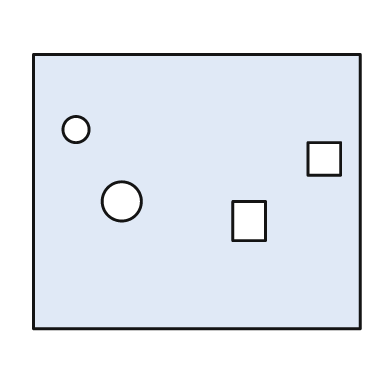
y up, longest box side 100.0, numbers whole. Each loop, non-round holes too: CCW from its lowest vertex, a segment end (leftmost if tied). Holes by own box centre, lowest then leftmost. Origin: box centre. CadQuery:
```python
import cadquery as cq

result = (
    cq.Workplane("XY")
    .moveTo(-50.0, -42.0)
    .lineTo(50.0, -42.0)
    .lineTo(50.0, 42.0)
    .lineTo(-50.0, 42.0)
    .close()
    .moveTo(11.0, -15.0)
    .lineTo(21.0, -15.0)
    .lineTo(21.0, -3.0)
    .lineTo(11.0, -3.0)
    .close()
    .moveTo(-23.0, -3.0)
    .circle(6.0)
    .moveTo(34.0, 5.0)
    .lineTo(44.0, 5.0)
    .lineTo(44.0, 15.0)
    .lineTo(34.0, 15.0)
    .close()
    .moveTo(-37.0, 19.0)
    .circle(4.0)
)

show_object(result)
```